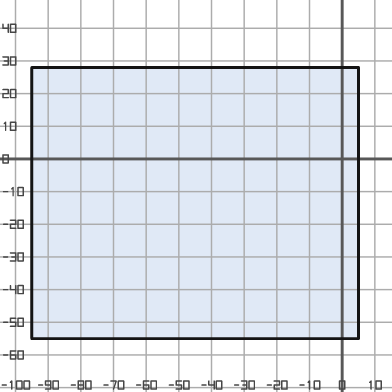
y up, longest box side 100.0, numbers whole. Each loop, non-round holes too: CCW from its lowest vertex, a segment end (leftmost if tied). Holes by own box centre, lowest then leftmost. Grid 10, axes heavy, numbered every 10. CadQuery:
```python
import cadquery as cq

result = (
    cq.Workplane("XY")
    .moveTo(-95.0, -55.0)
    .lineTo(5.0, -55.0)
    .lineTo(5.0, 28.0)
    .lineTo(-95.0, 28.0)
    .close()
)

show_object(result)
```